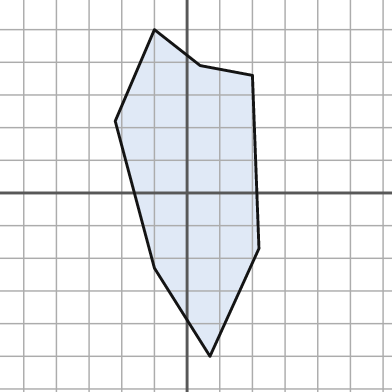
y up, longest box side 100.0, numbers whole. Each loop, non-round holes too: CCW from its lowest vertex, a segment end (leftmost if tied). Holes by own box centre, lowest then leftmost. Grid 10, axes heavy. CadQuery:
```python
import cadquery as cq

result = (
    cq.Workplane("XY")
    .moveTo(7.0, -50.0)
    .lineTo(22.0, -17.0)
    .lineTo(20.0, 36.0)
    .lineTo(4.0, 39.0)
    .lineTo(-10.0, 50.0)
    .lineTo(-22.0, 22.0)
    .lineTo(-10.0, -23.0)
    .close()
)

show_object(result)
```